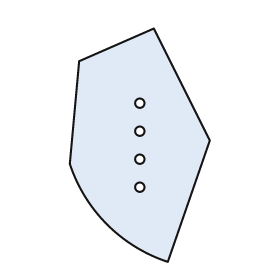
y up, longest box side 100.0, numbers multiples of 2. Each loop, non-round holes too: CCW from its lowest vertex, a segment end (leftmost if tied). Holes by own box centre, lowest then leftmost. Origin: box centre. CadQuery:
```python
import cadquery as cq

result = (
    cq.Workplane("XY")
    .moveTo(12.0, -50.0)
    .lineTo(30.0, 2.0)
    .lineTo(6.0, 50.0)
    .lineTo(-26.0, 36.0)
    .lineTo(-30.0, -8.0)
    .threePointArc((-14.0, -34.0), (12.0, -50.0))
    .close()
    .moveTo(0.0, -18.0)
    .circle(2.0)
    .moveTo(0.0, -6.0)
    .circle(2.0)
    .moveTo(0.0, 6.0)
    .circle(2.0)
    .moveTo(0.0, 18.0)
    .circle(2.0)
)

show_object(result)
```